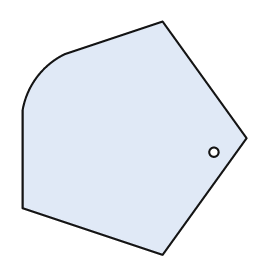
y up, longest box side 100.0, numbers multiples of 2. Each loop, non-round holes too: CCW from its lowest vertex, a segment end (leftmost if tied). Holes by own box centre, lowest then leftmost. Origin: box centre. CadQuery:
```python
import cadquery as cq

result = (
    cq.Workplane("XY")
    .moveTo(12.0, -50.0)
    .lineTo(48.0, 0.0)
    .lineTo(12.0, 50.0)
    .lineTo(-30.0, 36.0)
    .threePointArc((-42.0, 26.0), (-48.0, 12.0))
    .lineTo(-48.0, -30.0)
    .close()
    .moveTo(34.0, -6.0)
    .circle(2.0)
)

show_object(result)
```